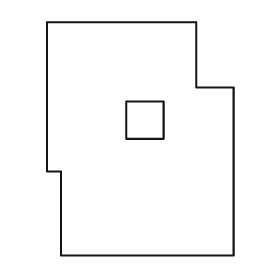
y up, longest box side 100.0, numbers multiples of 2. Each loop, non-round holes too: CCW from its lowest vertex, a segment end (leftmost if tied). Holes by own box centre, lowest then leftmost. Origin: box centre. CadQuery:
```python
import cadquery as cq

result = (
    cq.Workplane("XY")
    .moveTo(-34.0, -50.0)
    .lineTo(40.0, -50.0)
    .lineTo(40.0, 22.0)
    .lineTo(24.0, 22.0)
    .lineTo(24.0, 50.0)
    .lineTo(-40.0, 50.0)
    .lineTo(-40.0, -14.0)
    .lineTo(-34.0, -14.0)
    .close()
    .moveTo(-6.0, 0.0)
    .lineTo(10.0, 0.0)
    .lineTo(10.0, 16.0)
    .lineTo(-6.0, 16.0)
    .close()
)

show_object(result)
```